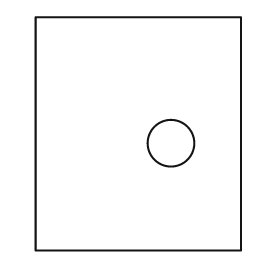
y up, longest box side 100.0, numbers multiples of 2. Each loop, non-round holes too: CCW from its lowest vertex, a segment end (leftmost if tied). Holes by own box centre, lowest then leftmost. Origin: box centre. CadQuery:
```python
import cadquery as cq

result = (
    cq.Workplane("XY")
    .moveTo(-44.0, -50.0)
    .lineTo(44.0, -50.0)
    .lineTo(44.0, 50.0)
    .lineTo(-44.0, 50.0)
    .close()
    .moveTo(14.0, -4.0)
    .circle(10.0)
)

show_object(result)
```